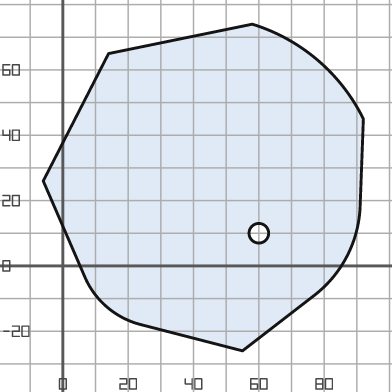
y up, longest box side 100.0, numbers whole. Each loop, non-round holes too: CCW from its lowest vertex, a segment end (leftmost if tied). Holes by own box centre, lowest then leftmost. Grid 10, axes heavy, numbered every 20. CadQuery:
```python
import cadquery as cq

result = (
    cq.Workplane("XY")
    .moveTo(55.0, -26.0)
    .lineTo(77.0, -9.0)
    .threePointArc((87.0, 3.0), (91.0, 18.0))
    .lineTo(92.0, 45.0)
    .threePointArc((78.0, 63.0), (58.0, 74.0))
    .lineTo(14.0, 65.0)
    .lineTo(-6.0, 26.0)
    .lineTo(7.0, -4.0)
    .threePointArc((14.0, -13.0), (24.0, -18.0))
    .close()
    .moveTo(60.0, 10.0)
    .circle(3.0)
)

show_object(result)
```